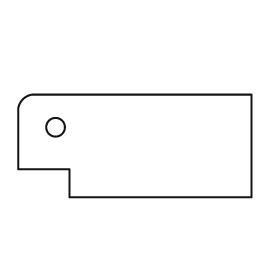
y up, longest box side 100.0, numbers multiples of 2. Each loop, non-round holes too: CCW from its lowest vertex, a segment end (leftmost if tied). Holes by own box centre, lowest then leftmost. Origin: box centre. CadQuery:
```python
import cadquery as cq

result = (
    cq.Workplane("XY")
    .moveTo(-28.0, -22.0)
    .lineTo(50.0, -22.0)
    .lineTo(50.0, 22.0)
    .lineTo(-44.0, 22.0)
    .threePointArc((-48.0, 20.0), (-50.0, 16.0))
    .lineTo(-50.0, -10.0)
    .lineTo(-28.0, -10.0)
    .close()
    .moveTo(-34.0, 8.0)
    .circle(4.0)
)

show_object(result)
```